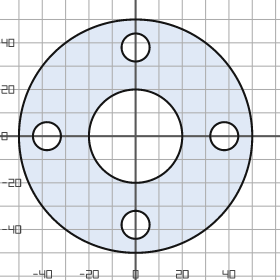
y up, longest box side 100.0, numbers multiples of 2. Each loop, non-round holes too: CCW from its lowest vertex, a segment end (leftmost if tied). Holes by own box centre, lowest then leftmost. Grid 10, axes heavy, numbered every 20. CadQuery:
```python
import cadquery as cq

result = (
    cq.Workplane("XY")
    .moveTo(0.0, 0.0)
    .circle(50.0)
    .moveTo(0.0, -38.0)
    .circle(6.0)
    .moveTo(-38.0, 0.0)
    .circle(6.0)
    .moveTo(0.0, 0.0)
    .circle(20.0)
    .moveTo(38.0, 0.0)
    .circle(6.0)
    .moveTo(0.0, 38.0)
    .circle(6.0)
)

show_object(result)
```